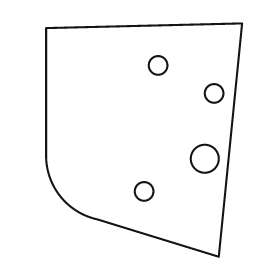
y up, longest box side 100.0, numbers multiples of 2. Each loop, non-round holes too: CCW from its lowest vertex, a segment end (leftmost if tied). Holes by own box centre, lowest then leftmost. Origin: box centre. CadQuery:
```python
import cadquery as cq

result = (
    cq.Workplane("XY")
    .moveTo(32.0, -50.0)
    .lineTo(42.0, 50.0)
    .lineTo(-42.0, 48.0)
    .lineTo(-42.0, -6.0)
    .threePointArc((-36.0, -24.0), (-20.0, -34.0))
    .close()
    .moveTo(0.0, -22.0)
    .circle(4.0)
    .moveTo(26.0, -8.0)
    .circle(6.0)
    .moveTo(30.0, 20.0)
    .circle(4.0)
    .moveTo(6.0, 32.0)
    .circle(4.0)
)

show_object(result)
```